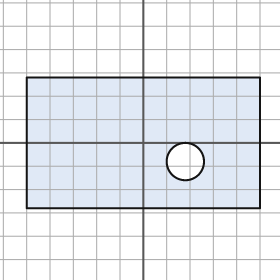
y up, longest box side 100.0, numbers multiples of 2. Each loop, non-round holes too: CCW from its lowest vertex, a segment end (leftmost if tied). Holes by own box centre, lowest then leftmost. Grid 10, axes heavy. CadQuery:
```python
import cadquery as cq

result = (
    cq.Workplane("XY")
    .moveTo(-50.0, -28.0)
    .lineTo(50.0, -28.0)
    .lineTo(50.0, 28.0)
    .lineTo(-50.0, 28.0)
    .close()
    .moveTo(18.0, -8.0)
    .circle(8.0)
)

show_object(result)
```